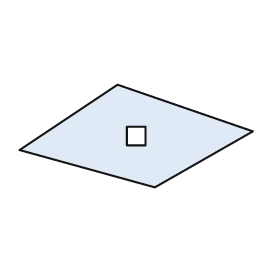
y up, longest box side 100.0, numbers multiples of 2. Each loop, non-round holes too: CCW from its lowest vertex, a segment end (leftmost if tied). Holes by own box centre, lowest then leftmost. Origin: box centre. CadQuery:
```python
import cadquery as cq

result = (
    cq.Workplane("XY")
    .moveTo(8.0, -22.0)
    .lineTo(50.0, 2.0)
    .lineTo(-8.0, 22.0)
    .lineTo(-50.0, -6.0)
    .close()
    .moveTo(-4.0, -4.0)
    .lineTo(4.0, -4.0)
    .lineTo(4.0, 4.0)
    .lineTo(-4.0, 4.0)
    .close()
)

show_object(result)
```